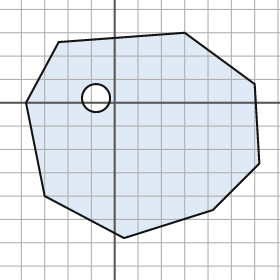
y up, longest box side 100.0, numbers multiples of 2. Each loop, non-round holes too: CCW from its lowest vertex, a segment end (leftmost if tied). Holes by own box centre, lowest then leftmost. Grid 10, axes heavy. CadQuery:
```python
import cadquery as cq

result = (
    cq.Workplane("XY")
    .moveTo(4.0, -58.0)
    .lineTo(42.0, -46.0)
    .lineTo(62.0, -26.0)
    .lineTo(60.0, 8.0)
    .lineTo(30.0, 30.0)
    .lineTo(-24.0, 26.0)
    .lineTo(-38.0, 0.0)
    .lineTo(-30.0, -40.0)
    .close()
    .moveTo(-8.0, 2.0)
    .circle(6.0)
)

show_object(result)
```